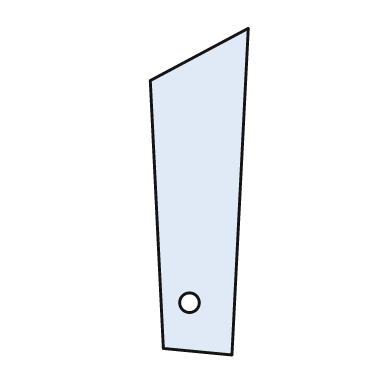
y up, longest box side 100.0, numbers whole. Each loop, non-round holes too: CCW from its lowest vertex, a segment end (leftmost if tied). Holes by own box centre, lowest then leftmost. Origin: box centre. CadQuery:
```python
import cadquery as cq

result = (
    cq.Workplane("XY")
    .moveTo(10.0, -50.0)
    .lineTo(15.0, 50.0)
    .lineTo(-15.0, 34.0)
    .lineTo(-11.0, -48.0)
    .close()
    .moveTo(-3.0, -34.0)
    .circle(3.0)
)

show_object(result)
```